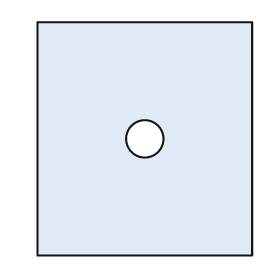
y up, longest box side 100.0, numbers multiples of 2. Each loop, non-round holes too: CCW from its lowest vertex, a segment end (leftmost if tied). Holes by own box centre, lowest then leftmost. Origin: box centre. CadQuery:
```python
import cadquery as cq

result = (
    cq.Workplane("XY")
    .moveTo(-46.0, -50.0)
    .lineTo(46.0, -50.0)
    .lineTo(46.0, 50.0)
    .lineTo(-46.0, 50.0)
    .close()
    .moveTo(0.0, 0.0)
    .circle(8.0)
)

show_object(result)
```